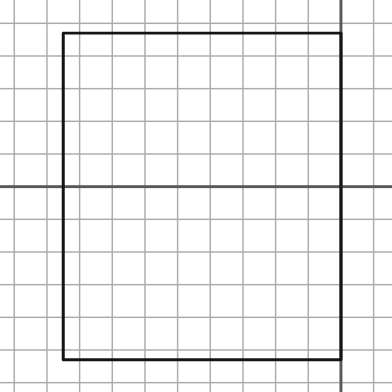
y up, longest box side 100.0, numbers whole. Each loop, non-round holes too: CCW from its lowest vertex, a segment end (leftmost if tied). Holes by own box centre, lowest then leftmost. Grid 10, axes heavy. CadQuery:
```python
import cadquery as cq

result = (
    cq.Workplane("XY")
    .moveTo(-85.0, -53.0)
    .lineTo(0.0, -53.0)
    .lineTo(0.0, 47.0)
    .lineTo(-85.0, 47.0)
    .close()
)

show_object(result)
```